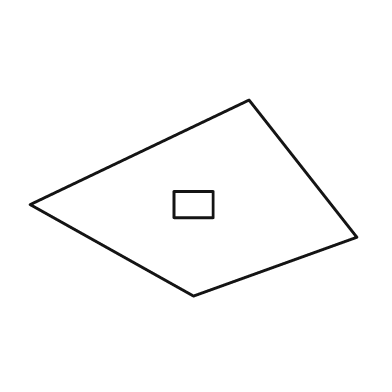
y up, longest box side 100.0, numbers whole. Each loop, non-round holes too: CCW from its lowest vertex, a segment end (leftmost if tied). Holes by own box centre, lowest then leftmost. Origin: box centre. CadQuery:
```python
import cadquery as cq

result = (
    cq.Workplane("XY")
    .moveTo(0.0, -30.0)
    .lineTo(50.0, -12.0)
    .lineTo(17.0, 30.0)
    .lineTo(-50.0, -2.0)
    .close()
    .moveTo(-6.0, -6.0)
    .lineTo(6.0, -6.0)
    .lineTo(6.0, 2.0)
    .lineTo(-6.0, 2.0)
    .close()
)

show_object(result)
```